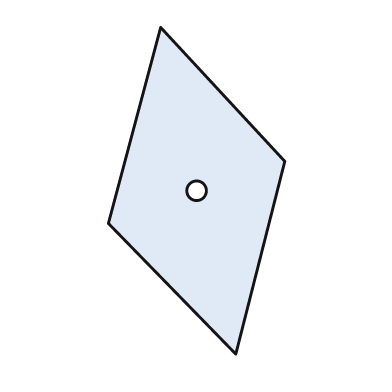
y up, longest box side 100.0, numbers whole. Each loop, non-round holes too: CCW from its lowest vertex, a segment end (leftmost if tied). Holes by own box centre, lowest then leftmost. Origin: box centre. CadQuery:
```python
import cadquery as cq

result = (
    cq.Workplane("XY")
    .moveTo(12.0, -50.0)
    .lineTo(27.0, 9.0)
    .lineTo(-11.0, 50.0)
    .lineTo(-27.0, -10.0)
    .close()
    .moveTo(0.0, 0.0)
    .circle(3.0)
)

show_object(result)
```